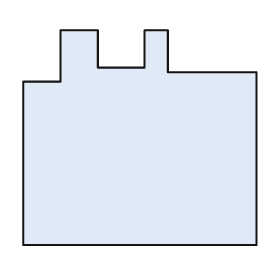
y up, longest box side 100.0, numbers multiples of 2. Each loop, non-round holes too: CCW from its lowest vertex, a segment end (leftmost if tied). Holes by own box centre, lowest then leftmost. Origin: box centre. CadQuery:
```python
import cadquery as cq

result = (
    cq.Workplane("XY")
    .moveTo(-50.0, -46.0)
    .lineTo(50.0, -46.0)
    .lineTo(50.0, 28.0)
    .lineTo(12.0, 28.0)
    .lineTo(12.0, 46.0)
    .lineTo(2.0, 46.0)
    .lineTo(2.0, 30.0)
    .lineTo(-18.0, 30.0)
    .lineTo(-18.0, 46.0)
    .lineTo(-34.0, 46.0)
    .lineTo(-34.0, 24.0)
    .lineTo(-50.0, 24.0)
    .close()
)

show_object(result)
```